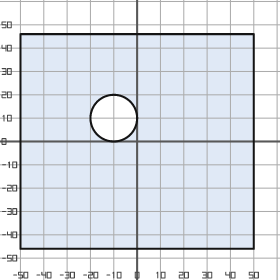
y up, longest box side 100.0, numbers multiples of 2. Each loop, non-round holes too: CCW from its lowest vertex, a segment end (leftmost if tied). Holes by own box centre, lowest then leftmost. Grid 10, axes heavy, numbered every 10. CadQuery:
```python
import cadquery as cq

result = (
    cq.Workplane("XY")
    .moveTo(-50.0, -46.0)
    .lineTo(50.0, -46.0)
    .lineTo(50.0, 46.0)
    .lineTo(-50.0, 46.0)
    .close()
    .moveTo(-10.0, 10.0)
    .circle(10.0)
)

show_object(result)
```